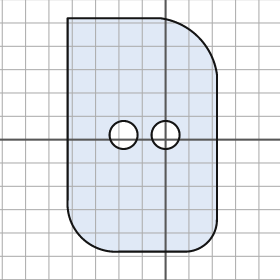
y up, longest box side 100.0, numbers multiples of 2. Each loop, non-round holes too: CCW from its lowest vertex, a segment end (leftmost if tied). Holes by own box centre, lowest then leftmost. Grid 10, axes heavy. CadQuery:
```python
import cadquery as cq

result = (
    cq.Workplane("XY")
    .moveTo(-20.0, -48.0)
    .lineTo(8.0, -48.0)
    .threePointArc((18.0, -44.0), (22.0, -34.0))
    .lineTo(22.0, 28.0)
    .threePointArc((14.0, 44.0), (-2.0, 52.0))
    .lineTo(-42.0, 52.0)
    .lineTo(-42.0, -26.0)
    .threePointArc((-36.0, -42.0), (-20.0, -48.0))
    .close()
    .moveTo(-18.0, 2.0)
    .circle(6.0)
    .moveTo(0.0, 2.0)
    .circle(6.0)
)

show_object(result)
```